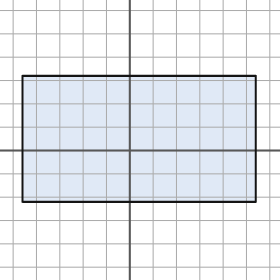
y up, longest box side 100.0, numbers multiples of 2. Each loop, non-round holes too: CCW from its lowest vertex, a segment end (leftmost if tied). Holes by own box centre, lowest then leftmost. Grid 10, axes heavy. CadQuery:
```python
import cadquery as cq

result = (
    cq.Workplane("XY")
    .moveTo(-46.0, -22.0)
    .lineTo(54.0, -22.0)
    .lineTo(54.0, 32.0)
    .lineTo(-46.0, 32.0)
    .close()
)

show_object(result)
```